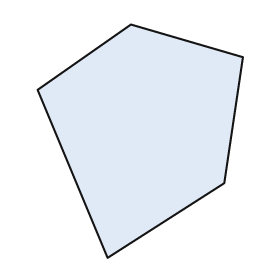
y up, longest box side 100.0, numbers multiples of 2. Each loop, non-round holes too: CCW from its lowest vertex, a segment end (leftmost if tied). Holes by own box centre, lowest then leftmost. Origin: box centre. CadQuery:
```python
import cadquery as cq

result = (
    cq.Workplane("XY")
    .moveTo(-14.0, -50.0)
    .lineTo(36.0, -18.0)
    .lineTo(44.0, 36.0)
    .lineTo(-4.0, 50.0)
    .lineTo(-44.0, 22.0)
    .close()
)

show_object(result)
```